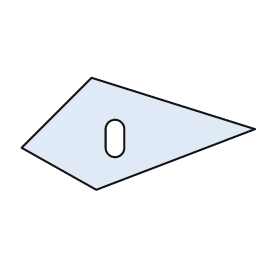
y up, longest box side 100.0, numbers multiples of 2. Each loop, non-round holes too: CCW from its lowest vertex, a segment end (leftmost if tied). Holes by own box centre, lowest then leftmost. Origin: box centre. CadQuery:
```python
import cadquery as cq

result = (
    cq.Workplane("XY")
    .moveTo(-18.0, -24.0)
    .lineTo(50.0, 2.0)
    .lineTo(-20.0, 24.0)
    .lineTo(-50.0, -6.0)
    .close()
    .moveTo(-14.0, -6.0)
    .threePointArc((-10.0, -10.0), (-6.0, -6.0))
    .lineTo(-6.0, 2.0)
    .threePointArc((-10.0, 6.0), (-14.0, 2.0))
    .close()
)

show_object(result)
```